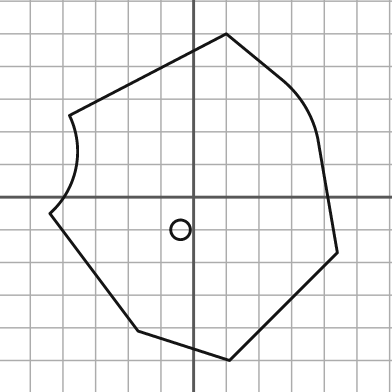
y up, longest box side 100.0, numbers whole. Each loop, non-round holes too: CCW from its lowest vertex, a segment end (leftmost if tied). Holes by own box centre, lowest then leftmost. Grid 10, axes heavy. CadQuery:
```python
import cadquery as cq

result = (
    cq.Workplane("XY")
    .moveTo(11.0, -50.0)
    .lineTo(44.0, -17.0)
    .lineTo(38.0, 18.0)
    .threePointArc((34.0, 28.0), (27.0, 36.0))
    .lineTo(10.0, 50.0)
    .lineTo(-38.0, 25.0)
    .threePointArc((-36.0, 9.0), (-44.0, -5.0))
    .lineTo(-17.0, -41.0)
    .close()
    .moveTo(-4.0, -10.0)
    .circle(3.0)
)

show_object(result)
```